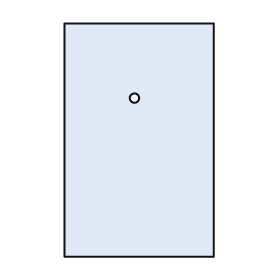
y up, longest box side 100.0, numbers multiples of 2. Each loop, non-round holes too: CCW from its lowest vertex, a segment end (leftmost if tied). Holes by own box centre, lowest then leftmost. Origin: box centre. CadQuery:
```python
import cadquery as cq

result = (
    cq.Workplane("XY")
    .moveTo(-32.0, -50.0)
    .lineTo(32.0, -50.0)
    .lineTo(32.0, 50.0)
    .lineTo(-32.0, 50.0)
    .close()
    .moveTo(-2.0, 18.0)
    .circle(2.0)
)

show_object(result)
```